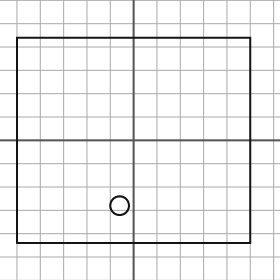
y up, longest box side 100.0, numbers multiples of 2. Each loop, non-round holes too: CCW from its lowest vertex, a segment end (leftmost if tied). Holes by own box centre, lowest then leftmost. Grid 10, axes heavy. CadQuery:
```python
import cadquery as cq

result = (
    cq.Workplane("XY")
    .moveTo(-50.0, -44.0)
    .lineTo(50.0, -44.0)
    .lineTo(50.0, 44.0)
    .lineTo(-50.0, 44.0)
    .close()
    .moveTo(-6.0, -28.0)
    .circle(4.0)
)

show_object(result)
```